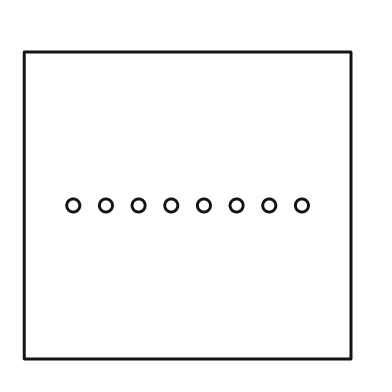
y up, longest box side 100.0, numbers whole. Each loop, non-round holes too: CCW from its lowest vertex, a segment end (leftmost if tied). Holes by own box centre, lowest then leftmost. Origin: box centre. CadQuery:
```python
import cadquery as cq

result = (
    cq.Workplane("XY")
    .moveTo(-50.0, -47.0)
    .lineTo(50.0, -47.0)
    .lineTo(50.0, 47.0)
    .lineTo(-50.0, 47.0)
    .close()
    .moveTo(-35.0, 0.0)
    .circle(2.0)
    .moveTo(-25.0, 0.0)
    .circle(2.0)
    .moveTo(-15.0, 0.0)
    .circle(2.0)
    .moveTo(-5.0, 0.0)
    .circle(2.0)
    .moveTo(5.0, 0.0)
    .circle(2.0)
    .moveTo(15.0, 0.0)
    .circle(2.0)
    .moveTo(25.0, 0.0)
    .circle(2.0)
    .moveTo(35.0, 0.0)
    .circle(2.0)
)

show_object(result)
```